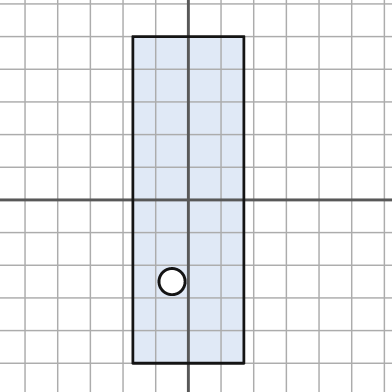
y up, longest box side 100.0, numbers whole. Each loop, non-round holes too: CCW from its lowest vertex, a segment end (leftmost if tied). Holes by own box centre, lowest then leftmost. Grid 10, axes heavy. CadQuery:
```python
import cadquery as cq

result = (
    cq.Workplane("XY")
    .moveTo(-17.0, -50.0)
    .lineTo(17.0, -50.0)
    .lineTo(17.0, 50.0)
    .lineTo(-17.0, 50.0)
    .close()
    .moveTo(-5.0, -25.0)
    .circle(4.0)
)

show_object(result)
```